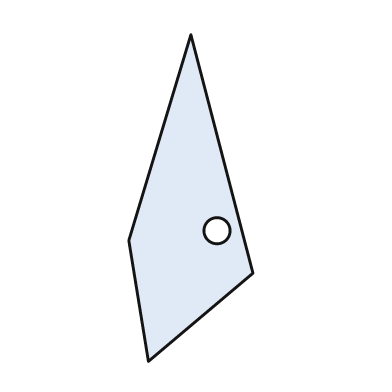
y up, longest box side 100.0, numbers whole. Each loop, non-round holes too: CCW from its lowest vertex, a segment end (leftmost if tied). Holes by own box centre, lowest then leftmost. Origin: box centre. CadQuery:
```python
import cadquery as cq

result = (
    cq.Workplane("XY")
    .moveTo(-13.0, -50.0)
    .lineTo(19.0, -23.0)
    .lineTo(0.0, 50.0)
    .lineTo(-19.0, -13.0)
    .close()
    .moveTo(8.0, -10.0)
    .circle(4.0)
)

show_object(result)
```